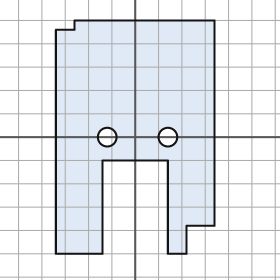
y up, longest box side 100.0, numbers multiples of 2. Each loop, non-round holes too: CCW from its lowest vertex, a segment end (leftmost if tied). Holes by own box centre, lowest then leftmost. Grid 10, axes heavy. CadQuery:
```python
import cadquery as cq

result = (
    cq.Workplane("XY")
    .moveTo(-34.0, -50.0)
    .lineTo(-14.0, -50.0)
    .lineTo(-14.0, -10.0)
    .lineTo(14.0, -10.0)
    .lineTo(14.0, -50.0)
    .lineTo(22.0, -50.0)
    .lineTo(22.0, -38.0)
    .lineTo(34.0, -38.0)
    .lineTo(34.0, 50.0)
    .lineTo(-26.0, 50.0)
    .lineTo(-26.0, 46.0)
    .lineTo(-34.0, 46.0)
    .close()
    .moveTo(-12.0, 0.0)
    .circle(4.0)
    .moveTo(14.0, 0.0)
    .circle(4.0)
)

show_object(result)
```